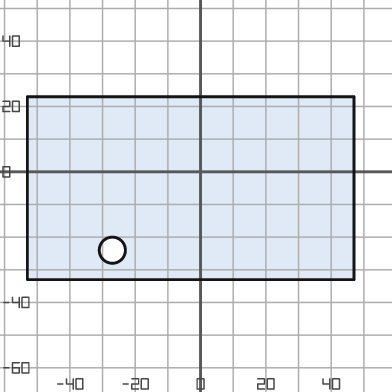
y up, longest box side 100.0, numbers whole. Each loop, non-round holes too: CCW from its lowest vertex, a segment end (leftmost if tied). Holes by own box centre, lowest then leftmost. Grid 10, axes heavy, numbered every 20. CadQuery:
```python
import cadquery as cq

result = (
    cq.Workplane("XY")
    .moveTo(-53.0, -33.0)
    .lineTo(47.0, -33.0)
    .lineTo(47.0, 23.0)
    .lineTo(-53.0, 23.0)
    .close()
    .moveTo(-27.0, -24.0)
    .circle(4.0)
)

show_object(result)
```